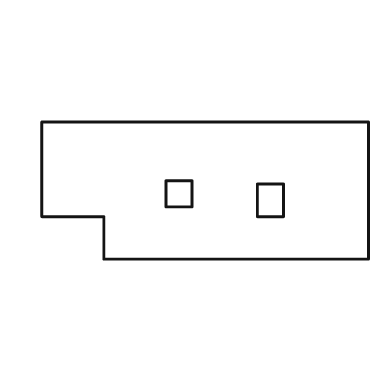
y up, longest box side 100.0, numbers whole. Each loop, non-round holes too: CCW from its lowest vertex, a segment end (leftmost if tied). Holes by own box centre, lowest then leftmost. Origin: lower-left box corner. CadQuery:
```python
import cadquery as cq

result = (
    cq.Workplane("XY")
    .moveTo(19.0, 0.0)
    .lineTo(100.0, 0.0)
    .lineTo(100.0, 42.0)
    .lineTo(0.0, 42.0)
    .lineTo(0.0, 13.0)
    .lineTo(19.0, 13.0)
    .close()
    .moveTo(66.0, 13.0)
    .lineTo(74.0, 13.0)
    .lineTo(74.0, 23.0)
    .lineTo(66.0, 23.0)
    .close()
    .moveTo(38.0, 16.0)
    .lineTo(46.0, 16.0)
    .lineTo(46.0, 24.0)
    .lineTo(38.0, 24.0)
    .close()
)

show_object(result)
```